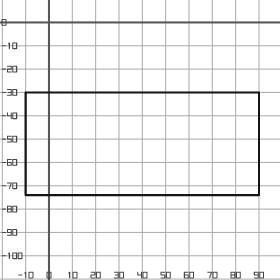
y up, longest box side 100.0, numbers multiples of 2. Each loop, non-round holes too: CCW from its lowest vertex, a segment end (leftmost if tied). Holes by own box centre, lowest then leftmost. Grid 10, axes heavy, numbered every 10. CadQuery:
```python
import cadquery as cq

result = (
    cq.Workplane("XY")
    .moveTo(-10.0, -74.0)
    .lineTo(90.0, -74.0)
    .lineTo(90.0, -30.0)
    .lineTo(-10.0, -30.0)
    .close()
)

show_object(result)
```